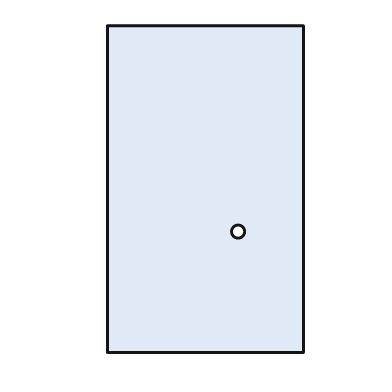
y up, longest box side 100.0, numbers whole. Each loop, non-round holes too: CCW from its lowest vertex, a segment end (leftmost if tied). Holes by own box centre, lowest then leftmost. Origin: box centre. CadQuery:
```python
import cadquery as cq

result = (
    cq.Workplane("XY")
    .moveTo(-30.0, -50.0)
    .lineTo(30.0, -50.0)
    .lineTo(30.0, 50.0)
    .lineTo(-30.0, 50.0)
    .close()
    .moveTo(10.0, -13.0)
    .circle(2.0)
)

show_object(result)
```